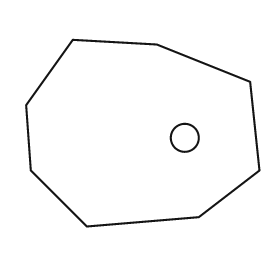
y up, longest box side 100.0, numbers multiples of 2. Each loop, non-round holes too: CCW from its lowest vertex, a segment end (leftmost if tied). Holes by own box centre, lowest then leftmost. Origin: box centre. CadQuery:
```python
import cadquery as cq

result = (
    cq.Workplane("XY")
    .moveTo(-24.0, -40.0)
    .lineTo(24.0, -36.0)
    .lineTo(50.0, -16.0)
    .lineTo(46.0, 22.0)
    .lineTo(6.0, 38.0)
    .lineTo(-30.0, 40.0)
    .lineTo(-50.0, 12.0)
    .lineTo(-48.0, -16.0)
    .close()
    .moveTo(18.0, -2.0)
    .circle(6.0)
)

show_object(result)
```